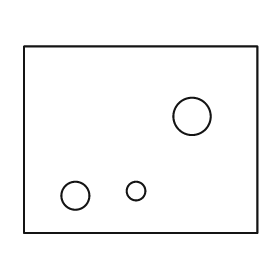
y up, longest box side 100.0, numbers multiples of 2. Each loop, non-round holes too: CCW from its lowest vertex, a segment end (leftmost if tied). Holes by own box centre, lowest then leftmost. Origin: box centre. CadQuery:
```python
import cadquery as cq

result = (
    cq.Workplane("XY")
    .moveTo(-50.0, -40.0)
    .lineTo(50.0, -40.0)
    .lineTo(50.0, 40.0)
    .lineTo(-50.0, 40.0)
    .close()
    .moveTo(-28.0, -24.0)
    .circle(6.0)
    .moveTo(-2.0, -22.0)
    .circle(4.0)
    .moveTo(22.0, 10.0)
    .circle(8.0)
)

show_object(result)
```